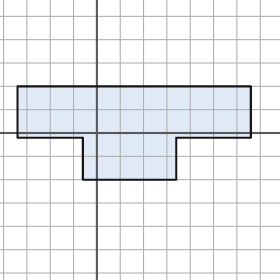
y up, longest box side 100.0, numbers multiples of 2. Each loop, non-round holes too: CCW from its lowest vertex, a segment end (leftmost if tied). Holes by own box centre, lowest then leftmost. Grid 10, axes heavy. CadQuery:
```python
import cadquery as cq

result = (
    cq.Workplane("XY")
    .moveTo(-6.0, -20.0)
    .lineTo(34.0, -20.0)
    .lineTo(34.0, -2.0)
    .lineTo(66.0, -2.0)
    .lineTo(66.0, 20.0)
    .lineTo(-34.0, 20.0)
    .lineTo(-34.0, -2.0)
    .lineTo(-6.0, -2.0)
    .close()
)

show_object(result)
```